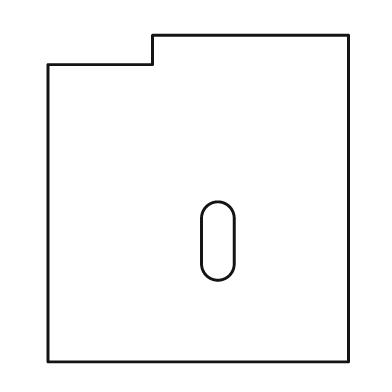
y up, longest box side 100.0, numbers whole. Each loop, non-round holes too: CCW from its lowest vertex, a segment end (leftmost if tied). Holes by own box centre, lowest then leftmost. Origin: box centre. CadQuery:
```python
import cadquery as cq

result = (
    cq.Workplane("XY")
    .moveTo(-46.0, -50.0)
    .lineTo(46.0, -50.0)
    .lineTo(46.0, 50.0)
    .lineTo(-14.0, 50.0)
    .lineTo(-14.0, 41.0)
    .lineTo(-46.0, 41.0)
    .close()
    .moveTo(1.0, -20.0)
    .threePointArc((6.0, -25.0), (11.0, -20.0))
    .lineTo(11.0, -6.0)
    .threePointArc((6.0, -1.0), (1.0, -6.0))
    .close()
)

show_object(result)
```